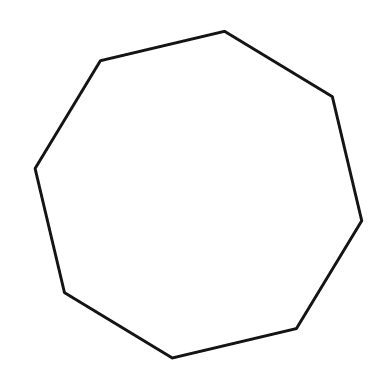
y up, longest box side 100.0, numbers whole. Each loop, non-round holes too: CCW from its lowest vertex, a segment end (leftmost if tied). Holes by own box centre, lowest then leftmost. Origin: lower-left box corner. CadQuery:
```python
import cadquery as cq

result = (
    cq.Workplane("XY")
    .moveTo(42.0, 0.0)
    .lineTo(80.0, 9.0)
    .lineTo(100.0, 42.0)
    .lineTo(91.0, 80.0)
    .lineTo(58.0, 100.0)
    .lineTo(20.0, 91.0)
    .lineTo(0.0, 58.0)
    .lineTo(9.0, 20.0)
    .close()
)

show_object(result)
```